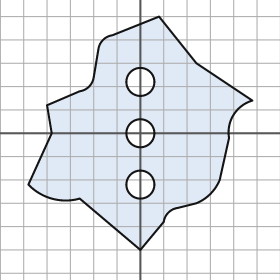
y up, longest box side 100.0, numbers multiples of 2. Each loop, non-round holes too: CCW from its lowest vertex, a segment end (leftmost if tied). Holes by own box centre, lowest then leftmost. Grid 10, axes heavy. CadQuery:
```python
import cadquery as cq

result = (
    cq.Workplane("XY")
    .moveTo(0.0, -50.0)
    .lineTo(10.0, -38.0)
    .threePointArc((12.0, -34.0), (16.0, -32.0))
    .lineTo(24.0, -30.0)
    .threePointArc((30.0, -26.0), (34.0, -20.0))
    .lineTo(38.0, -2.0)
    .threePointArc((40.0, 8.0), (48.0, 14.0))
    .lineTo(24.0, 30.0)
    .lineTo(8.0, 50.0)
    .lineTo(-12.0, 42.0)
    .threePointArc((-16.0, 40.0), (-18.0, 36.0))
    .lineTo(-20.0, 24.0)
    .threePointArc((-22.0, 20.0), (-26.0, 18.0))
    .lineTo(-40.0, 12.0)
    .lineTo(-38.0, 0.0)
    .lineTo(-48.0, -22.0)
    .threePointArc((-38.0, -28.0), (-26.0, -28.0))
    .close()
    .moveTo(0.0, -22.0)
    .circle(6.0)
    .moveTo(0.0, 0.0)
    .circle(6.0)
    .moveTo(0.0, 22.0)
    .circle(6.0)
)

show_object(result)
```